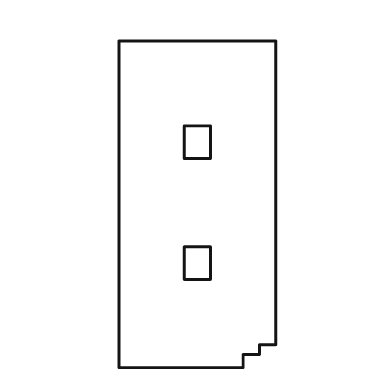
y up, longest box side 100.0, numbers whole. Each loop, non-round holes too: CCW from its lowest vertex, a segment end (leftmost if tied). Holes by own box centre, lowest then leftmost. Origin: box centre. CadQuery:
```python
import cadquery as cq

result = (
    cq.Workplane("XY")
    .moveTo(-24.0, -50.0)
    .lineTo(14.0, -50.0)
    .lineTo(14.0, -46.0)
    .lineTo(19.0, -46.0)
    .lineTo(19.0, -43.0)
    .lineTo(24.0, -43.0)
    .lineTo(24.0, 50.0)
    .lineTo(-24.0, 50.0)
    .close()
    .moveTo(-4.0, -23.0)
    .lineTo(4.0, -23.0)
    .lineTo(4.0, -13.0)
    .lineTo(-4.0, -13.0)
    .close()
    .moveTo(-4.0, 14.0)
    .lineTo(4.0, 14.0)
    .lineTo(4.0, 24.0)
    .lineTo(-4.0, 24.0)
    .close()
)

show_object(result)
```